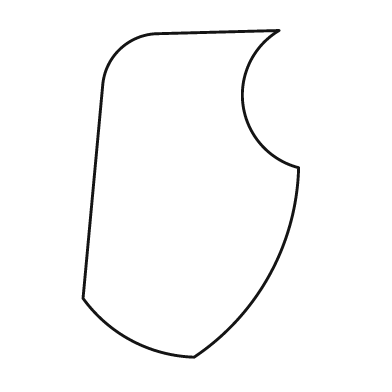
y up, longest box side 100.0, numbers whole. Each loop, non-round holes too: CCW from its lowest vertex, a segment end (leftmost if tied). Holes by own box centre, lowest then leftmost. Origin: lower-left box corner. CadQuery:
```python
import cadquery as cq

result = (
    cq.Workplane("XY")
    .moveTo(34.0, 0.0)
    .threePointArc((57.0, 25.0), (66.0, 58.0))
    .threePointArc((49.0, 77.0), (60.0, 100.0))
    .lineTo(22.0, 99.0)
    .threePointArc((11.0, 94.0), (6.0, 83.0))
    .lineTo(0.0, 18.0)
    .threePointArc((15.0, 5.0), (34.0, 0.0))
    .close()
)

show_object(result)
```